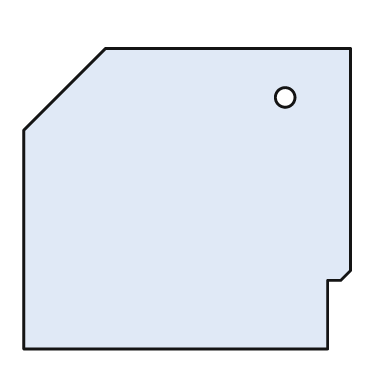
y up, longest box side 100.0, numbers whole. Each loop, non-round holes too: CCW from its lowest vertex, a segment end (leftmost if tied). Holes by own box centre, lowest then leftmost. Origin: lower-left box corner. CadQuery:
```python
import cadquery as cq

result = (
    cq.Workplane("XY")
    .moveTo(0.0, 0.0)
    .lineTo(93.0, 0.0)
    .lineTo(93.0, 21.0)
    .lineTo(97.0, 21.0)
    .lineTo(100.0, 24.0)
    .lineTo(100.0, 92.0)
    .lineTo(25.0, 92.0)
    .lineTo(0.0, 67.0)
    .close()
    .moveTo(80.0, 77.0)
    .circle(3.0)
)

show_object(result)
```